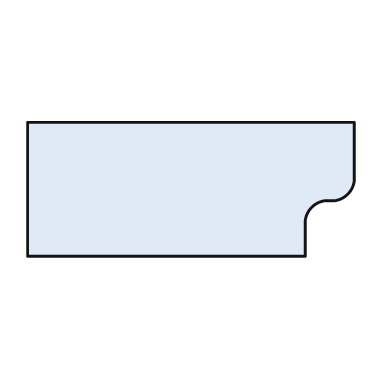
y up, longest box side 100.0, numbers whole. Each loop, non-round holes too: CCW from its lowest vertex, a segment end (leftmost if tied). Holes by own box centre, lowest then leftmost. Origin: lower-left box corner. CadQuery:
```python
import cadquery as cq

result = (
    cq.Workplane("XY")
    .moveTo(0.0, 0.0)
    .lineTo(85.0, 0.0)
    .lineTo(85.0, 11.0)
    .threePointArc((87.0, 15.0), (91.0, 17.0))
    .lineTo(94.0, 17.0)
    .threePointArc((98.0, 19.0), (100.0, 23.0))
    .lineTo(100.0, 41.0)
    .lineTo(0.0, 41.0)
    .close()
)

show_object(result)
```